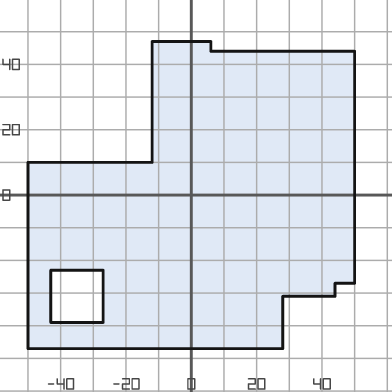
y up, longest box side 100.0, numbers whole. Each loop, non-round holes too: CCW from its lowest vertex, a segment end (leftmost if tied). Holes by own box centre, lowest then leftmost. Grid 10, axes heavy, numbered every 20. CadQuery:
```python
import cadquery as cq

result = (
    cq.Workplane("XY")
    .moveTo(-50.0, -47.0)
    .lineTo(28.0, -47.0)
    .lineTo(28.0, -31.0)
    .lineTo(44.0, -31.0)
    .lineTo(44.0, -27.0)
    .lineTo(50.0, -27.0)
    .lineTo(50.0, 44.0)
    .lineTo(6.0, 44.0)
    .lineTo(6.0, 47.0)
    .lineTo(-12.0, 47.0)
    .lineTo(-12.0, 10.0)
    .lineTo(-50.0, 10.0)
    .close()
    .moveTo(-43.0, -39.0)
    .lineTo(-27.0, -39.0)
    .lineTo(-27.0, -23.0)
    .lineTo(-43.0, -23.0)
    .close()
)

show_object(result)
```